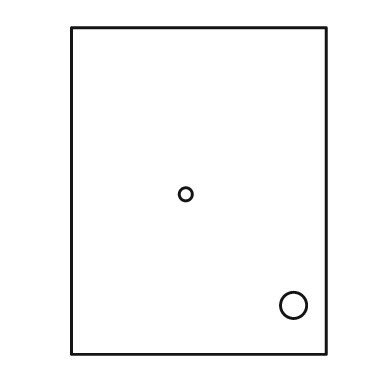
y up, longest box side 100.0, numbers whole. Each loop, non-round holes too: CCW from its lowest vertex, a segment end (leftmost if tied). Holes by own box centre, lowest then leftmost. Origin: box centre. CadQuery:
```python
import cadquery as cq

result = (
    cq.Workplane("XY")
    .moveTo(-39.0, -50.0)
    .lineTo(39.0, -50.0)
    .lineTo(39.0, 50.0)
    .lineTo(-39.0, 50.0)
    .close()
    .moveTo(29.0, -35.0)
    .circle(4.0)
    .moveTo(-4.0, -1.0)
    .circle(2.0)
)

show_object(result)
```